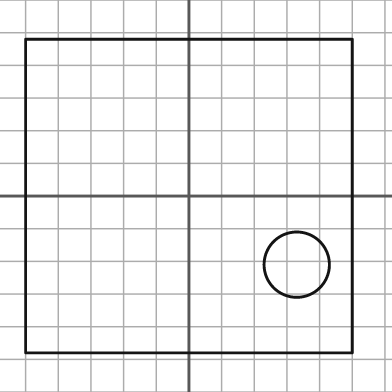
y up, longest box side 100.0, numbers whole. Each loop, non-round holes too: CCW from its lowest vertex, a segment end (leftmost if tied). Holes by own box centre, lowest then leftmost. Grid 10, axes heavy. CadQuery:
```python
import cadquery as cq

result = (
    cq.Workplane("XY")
    .moveTo(-50.0, -48.0)
    .lineTo(50.0, -48.0)
    .lineTo(50.0, 48.0)
    .lineTo(-50.0, 48.0)
    .close()
    .moveTo(33.0, -21.0)
    .circle(10.0)
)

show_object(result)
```